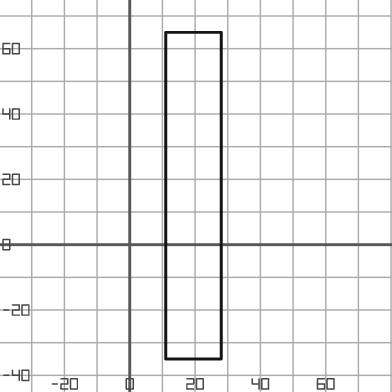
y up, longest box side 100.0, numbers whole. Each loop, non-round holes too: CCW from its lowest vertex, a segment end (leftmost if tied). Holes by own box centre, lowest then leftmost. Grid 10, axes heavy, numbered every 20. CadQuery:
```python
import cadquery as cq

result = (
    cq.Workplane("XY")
    .moveTo(11.0, -35.0)
    .lineTo(28.0, -35.0)
    .lineTo(28.0, 65.0)
    .lineTo(11.0, 65.0)
    .close()
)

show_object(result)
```